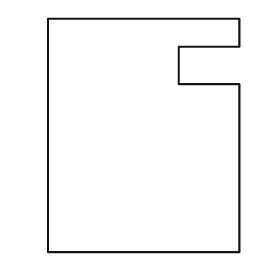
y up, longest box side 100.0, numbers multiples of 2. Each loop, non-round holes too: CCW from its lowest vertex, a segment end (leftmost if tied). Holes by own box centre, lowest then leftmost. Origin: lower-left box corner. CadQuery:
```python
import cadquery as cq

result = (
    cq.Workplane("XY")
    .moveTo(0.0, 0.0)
    .lineTo(82.0, 0.0)
    .lineTo(82.0, 72.0)
    .lineTo(56.0, 72.0)
    .lineTo(56.0, 88.0)
    .lineTo(82.0, 88.0)
    .lineTo(82.0, 100.0)
    .lineTo(0.0, 100.0)
    .close()
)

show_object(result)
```